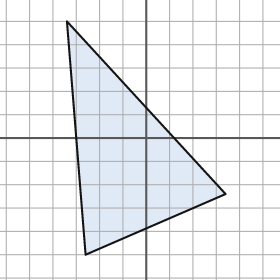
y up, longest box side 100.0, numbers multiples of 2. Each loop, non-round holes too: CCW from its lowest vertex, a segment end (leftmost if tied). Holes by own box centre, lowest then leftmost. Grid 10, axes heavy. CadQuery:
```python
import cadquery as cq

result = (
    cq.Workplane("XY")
    .moveTo(-26.0, -50.0)
    .lineTo(34.0, -24.0)
    .lineTo(-34.0, 50.0)
    .close()
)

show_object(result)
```